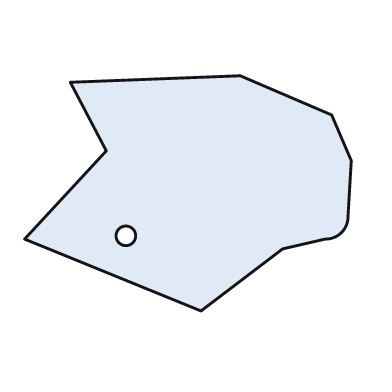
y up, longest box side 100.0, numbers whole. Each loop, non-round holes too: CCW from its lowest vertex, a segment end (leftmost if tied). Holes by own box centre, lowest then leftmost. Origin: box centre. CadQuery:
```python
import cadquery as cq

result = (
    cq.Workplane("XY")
    .moveTo(4.0, -36.0)
    .lineTo(29.0, -17.0)
    .lineTo(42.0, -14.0)
    .threePointArc((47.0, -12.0), (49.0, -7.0))
    .lineTo(50.0, 10.0)
    .lineTo(44.0, 24.0)
    .lineTo(16.0, 36.0)
    .lineTo(-36.0, 34.0)
    .lineTo(-25.0, 13.0)
    .lineTo(-50.0, -14.0)
    .close()
    .moveTo(-19.0, -13.0)
    .circle(3.0)
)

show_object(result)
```